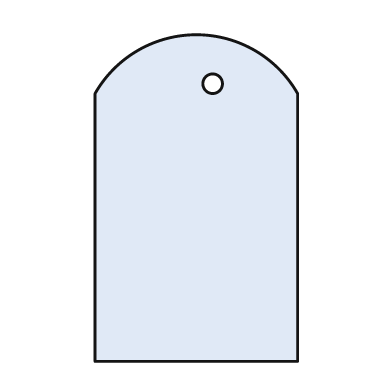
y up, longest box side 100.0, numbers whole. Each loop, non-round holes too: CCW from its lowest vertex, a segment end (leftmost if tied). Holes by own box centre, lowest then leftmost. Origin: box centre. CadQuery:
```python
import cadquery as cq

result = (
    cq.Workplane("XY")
    .moveTo(-31.0, -50.0)
    .lineTo(31.0, -50.0)
    .lineTo(31.0, 32.0)
    .threePointArc((0.0, 50.0), (-31.0, 32.0))
    .close()
    .moveTo(5.0, 35.0)
    .circle(3.0)
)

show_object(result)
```